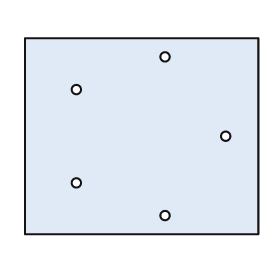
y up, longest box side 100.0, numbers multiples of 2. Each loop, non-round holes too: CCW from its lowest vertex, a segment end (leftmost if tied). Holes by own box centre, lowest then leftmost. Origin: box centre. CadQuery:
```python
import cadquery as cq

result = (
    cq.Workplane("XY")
    .moveTo(-50.0, -42.0)
    .lineTo(50.0, -42.0)
    .lineTo(50.0, 42.0)
    .lineTo(-50.0, 42.0)
    .close()
    .moveTo(10.0, -34.0)
    .circle(2.0)
    .moveTo(-28.0, -20.0)
    .circle(2.0)
    .moveTo(36.0, 0.0)
    .circle(2.0)
    .moveTo(-28.0, 20.0)
    .circle(2.0)
    .moveTo(10.0, 34.0)
    .circle(2.0)
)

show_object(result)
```